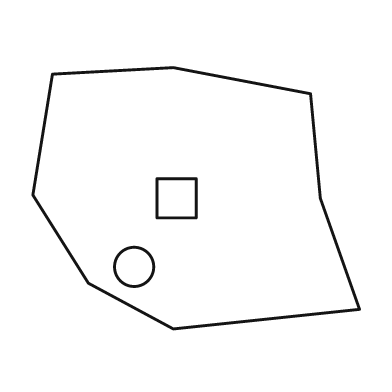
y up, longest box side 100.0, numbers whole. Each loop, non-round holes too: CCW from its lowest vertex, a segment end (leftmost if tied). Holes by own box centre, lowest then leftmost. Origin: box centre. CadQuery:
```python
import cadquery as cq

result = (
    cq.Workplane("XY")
    .moveTo(-7.0, -40.0)
    .lineTo(50.0, -34.0)
    .lineTo(38.0, 0.0)
    .lineTo(35.0, 32.0)
    .lineTo(-7.0, 40.0)
    .lineTo(-44.0, 38.0)
    .lineTo(-50.0, 1.0)
    .lineTo(-33.0, -26.0)
    .close()
    .moveTo(-19.0, -21.0)
    .circle(6.0)
    .moveTo(-12.0, -6.0)
    .lineTo(0.0, -6.0)
    .lineTo(0.0, 6.0)
    .lineTo(-12.0, 6.0)
    .close()
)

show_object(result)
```